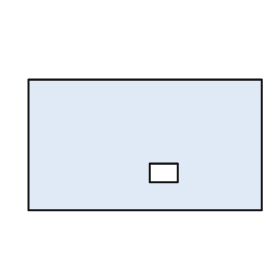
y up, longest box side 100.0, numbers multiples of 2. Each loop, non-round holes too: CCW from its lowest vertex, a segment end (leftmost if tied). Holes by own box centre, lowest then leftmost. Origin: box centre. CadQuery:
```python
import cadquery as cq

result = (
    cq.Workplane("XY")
    .moveTo(-50.0, -28.0)
    .lineTo(50.0, -28.0)
    .lineTo(50.0, 28.0)
    .lineTo(-50.0, 28.0)
    .close()
    .moveTo(2.0, -16.0)
    .lineTo(14.0, -16.0)
    .lineTo(14.0, -8.0)
    .lineTo(2.0, -8.0)
    .close()
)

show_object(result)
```